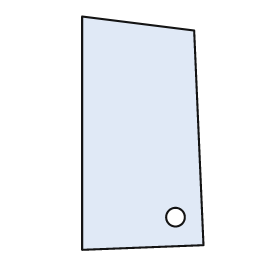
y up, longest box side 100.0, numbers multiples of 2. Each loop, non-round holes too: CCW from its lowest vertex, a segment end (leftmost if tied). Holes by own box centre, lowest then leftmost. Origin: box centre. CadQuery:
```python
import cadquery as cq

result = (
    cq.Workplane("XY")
    .moveTo(-26.0, -50.0)
    .lineTo(26.0, -48.0)
    .lineTo(22.0, 44.0)
    .lineTo(-26.0, 50.0)
    .close()
    .moveTo(14.0, -36.0)
    .circle(4.0)
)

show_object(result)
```